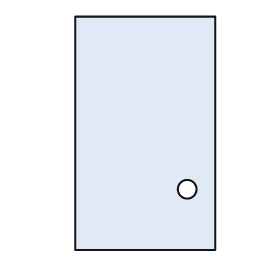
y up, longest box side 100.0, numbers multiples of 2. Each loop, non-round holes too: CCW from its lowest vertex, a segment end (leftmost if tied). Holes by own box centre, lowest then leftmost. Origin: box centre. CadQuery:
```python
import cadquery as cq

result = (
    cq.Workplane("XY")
    .moveTo(-30.0, -50.0)
    .lineTo(30.0, -50.0)
    .lineTo(30.0, 50.0)
    .lineTo(-30.0, 50.0)
    .close()
    .moveTo(18.0, -24.0)
    .circle(4.0)
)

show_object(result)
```